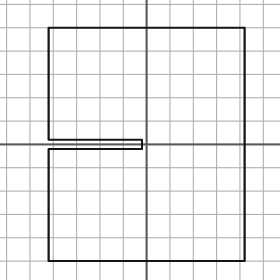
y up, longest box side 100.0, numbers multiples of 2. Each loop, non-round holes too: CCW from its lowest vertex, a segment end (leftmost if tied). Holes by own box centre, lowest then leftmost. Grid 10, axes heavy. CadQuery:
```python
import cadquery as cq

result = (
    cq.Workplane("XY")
    .moveTo(-42.0, -50.0)
    .lineTo(42.0, -50.0)
    .lineTo(42.0, 50.0)
    .lineTo(-42.0, 50.0)
    .lineTo(-42.0, 2.0)
    .lineTo(-2.0, 2.0)
    .lineTo(-2.0, -2.0)
    .lineTo(-42.0, -2.0)
    .close()
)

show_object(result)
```